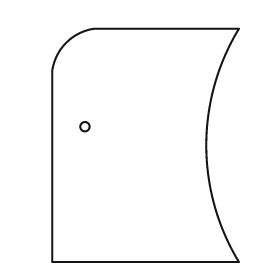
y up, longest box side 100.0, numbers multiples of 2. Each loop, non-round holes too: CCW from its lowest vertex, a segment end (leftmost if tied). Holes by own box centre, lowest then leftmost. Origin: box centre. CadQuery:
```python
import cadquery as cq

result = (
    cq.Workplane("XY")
    .moveTo(-40.0, -50.0)
    .lineTo(40.0, -50.0)
    .threePointArc((26.0, 0.0), (40.0, 50.0))
    .lineTo(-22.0, 50.0)
    .threePointArc((-34.0, 44.0), (-40.0, 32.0))
    .close()
    .moveTo(-26.0, 8.0)
    .circle(2.0)
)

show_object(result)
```